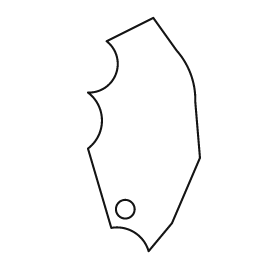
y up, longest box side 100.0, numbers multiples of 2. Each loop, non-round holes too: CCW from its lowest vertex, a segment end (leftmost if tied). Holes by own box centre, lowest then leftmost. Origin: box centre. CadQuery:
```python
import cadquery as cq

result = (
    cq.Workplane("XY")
    .moveTo(2.0, -50.0)
    .lineTo(12.0, -38.0)
    .lineTo(24.0, -10.0)
    .lineTo(22.0, 14.0)
    .threePointArc((20.0, 26.0), (14.0, 36.0))
    .lineTo(4.0, 50.0)
    .lineTo(-16.0, 40.0)
    .threePointArc((-12.0, 26.0), (-24.0, 18.0))
    .threePointArc((-18.0, 6.0), (-24.0, -6.0))
    .lineTo(-14.0, -40.0)
    .threePointArc((-4.0, -42.0), (2.0, -50.0))
    .close()
    .moveTo(-8.0, -32.0)
    .circle(4.0)
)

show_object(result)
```